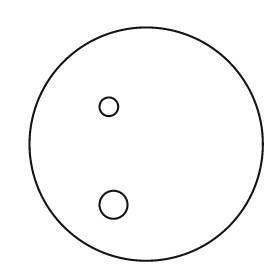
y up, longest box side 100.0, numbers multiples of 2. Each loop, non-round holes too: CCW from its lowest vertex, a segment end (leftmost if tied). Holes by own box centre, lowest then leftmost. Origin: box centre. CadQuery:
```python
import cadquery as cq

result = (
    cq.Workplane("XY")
    .moveTo(0.0, 0.0)
    .circle(50.0)
    .moveTo(-14.0, -26.0)
    .circle(6.0)
    .moveTo(-16.0, 16.0)
    .circle(4.0)
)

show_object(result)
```